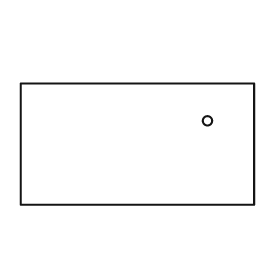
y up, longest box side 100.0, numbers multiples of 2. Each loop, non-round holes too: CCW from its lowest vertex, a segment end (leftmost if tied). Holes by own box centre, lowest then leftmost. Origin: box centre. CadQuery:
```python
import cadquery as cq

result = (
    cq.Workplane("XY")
    .moveTo(-50.0, -26.0)
    .lineTo(50.0, -26.0)
    .lineTo(50.0, 26.0)
    .lineTo(-50.0, 26.0)
    .close()
    .moveTo(30.0, 10.0)
    .circle(2.0)
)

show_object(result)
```